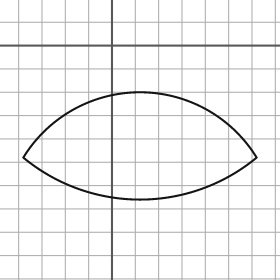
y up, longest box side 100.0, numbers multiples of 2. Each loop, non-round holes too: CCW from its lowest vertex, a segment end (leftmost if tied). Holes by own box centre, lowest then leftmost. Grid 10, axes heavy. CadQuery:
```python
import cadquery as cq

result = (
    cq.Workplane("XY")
    .moveTo(-38.0, -48.0)
    .threePointArc((12.0, -66.0), (62.0, -48.0))
    .threePointArc((12.0, -20.0), (-38.0, -48.0))
    .close()
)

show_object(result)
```